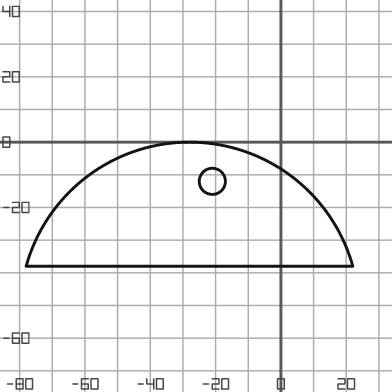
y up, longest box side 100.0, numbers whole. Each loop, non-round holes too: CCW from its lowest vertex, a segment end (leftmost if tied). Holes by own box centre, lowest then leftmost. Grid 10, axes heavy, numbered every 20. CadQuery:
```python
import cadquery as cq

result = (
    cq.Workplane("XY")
    .moveTo(-78.0, -38.0)
    .lineTo(22.0, -38.0)
    .threePointArc((-28.0, 0.0), (-78.0, -38.0))
    .close()
    .moveTo(-21.0, -12.0)
    .circle(4.0)
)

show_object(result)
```